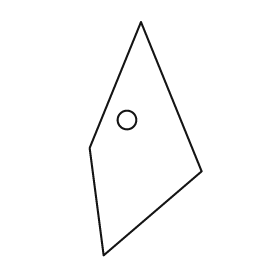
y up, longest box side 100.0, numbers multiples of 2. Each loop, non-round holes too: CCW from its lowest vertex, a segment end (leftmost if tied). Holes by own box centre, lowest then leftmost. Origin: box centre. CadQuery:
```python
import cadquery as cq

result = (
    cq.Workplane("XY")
    .moveTo(-18.0, -50.0)
    .lineTo(24.0, -14.0)
    .lineTo(-2.0, 50.0)
    .lineTo(-24.0, -4.0)
    .close()
    .moveTo(-8.0, 8.0)
    .circle(4.0)
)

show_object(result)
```